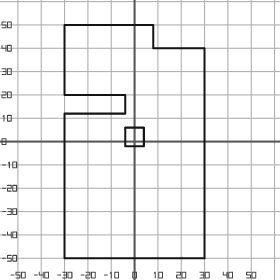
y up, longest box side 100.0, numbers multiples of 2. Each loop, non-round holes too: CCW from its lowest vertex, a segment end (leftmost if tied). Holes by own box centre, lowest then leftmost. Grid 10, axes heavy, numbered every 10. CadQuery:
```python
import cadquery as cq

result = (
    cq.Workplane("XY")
    .moveTo(-30.0, -50.0)
    .lineTo(30.0, -50.0)
    .lineTo(30.0, 40.0)
    .lineTo(8.0, 40.0)
    .lineTo(8.0, 50.0)
    .lineTo(-30.0, 50.0)
    .lineTo(-30.0, 20.0)
    .lineTo(-4.0, 20.0)
    .lineTo(-4.0, 12.0)
    .lineTo(-30.0, 12.0)
    .close()
    .moveTo(-4.0, -2.0)
    .lineTo(4.0, -2.0)
    .lineTo(4.0, 6.0)
    .lineTo(-4.0, 6.0)
    .close()
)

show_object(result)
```